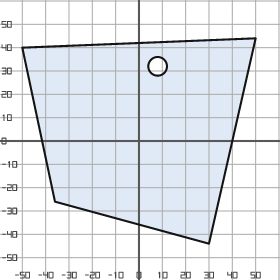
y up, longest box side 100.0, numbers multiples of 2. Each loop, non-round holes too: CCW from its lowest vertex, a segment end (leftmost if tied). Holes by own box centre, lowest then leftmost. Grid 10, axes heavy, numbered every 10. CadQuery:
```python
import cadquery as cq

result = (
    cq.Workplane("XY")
    .moveTo(30.0, -44.0)
    .lineTo(50.0, 44.0)
    .lineTo(-50.0, 40.0)
    .lineTo(-36.0, -26.0)
    .close()
    .moveTo(8.0, 32.0)
    .circle(4.0)
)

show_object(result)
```